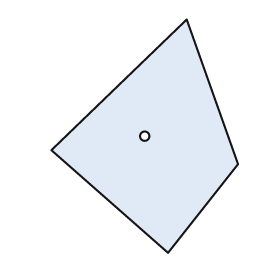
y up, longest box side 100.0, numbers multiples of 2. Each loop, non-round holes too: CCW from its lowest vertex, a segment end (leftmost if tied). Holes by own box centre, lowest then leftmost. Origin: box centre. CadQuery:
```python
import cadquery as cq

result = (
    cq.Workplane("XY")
    .moveTo(10.0, -50.0)
    .lineTo(40.0, -12.0)
    .lineTo(18.0, 50.0)
    .lineTo(-40.0, -6.0)
    .close()
    .moveTo(0.0, 0.0)
    .circle(2.0)
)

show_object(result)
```